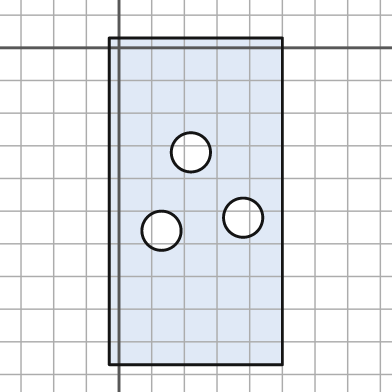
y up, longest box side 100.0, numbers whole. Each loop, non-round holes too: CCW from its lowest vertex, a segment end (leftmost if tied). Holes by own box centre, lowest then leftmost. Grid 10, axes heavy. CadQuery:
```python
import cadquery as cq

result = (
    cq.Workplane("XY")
    .moveTo(-3.0, -97.0)
    .lineTo(50.0, -97.0)
    .lineTo(50.0, 3.0)
    .lineTo(-3.0, 3.0)
    .close()
    .moveTo(13.0, -56.0)
    .circle(6.0)
    .moveTo(38.0, -52.0)
    .circle(6.0)
    .moveTo(22.0, -32.0)
    .circle(6.0)
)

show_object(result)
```